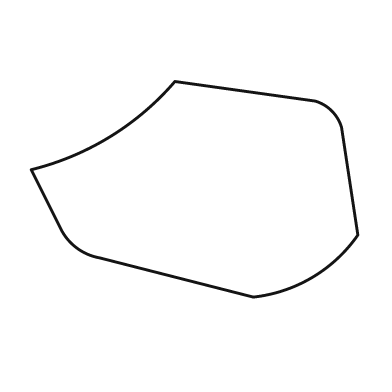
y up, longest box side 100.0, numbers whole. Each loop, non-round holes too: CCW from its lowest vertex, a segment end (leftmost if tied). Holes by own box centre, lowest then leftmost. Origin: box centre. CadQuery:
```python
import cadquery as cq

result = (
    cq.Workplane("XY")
    .moveTo(18.0, -33.0)
    .threePointArc((36.0, -27.0), (50.0, -14.0))
    .lineTo(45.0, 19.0)
    .threePointArc((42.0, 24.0), (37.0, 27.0))
    .lineTo(-6.0, 33.0)
    .threePointArc((-26.0, 16.0), (-50.0, 6.0))
    .lineTo(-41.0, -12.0)
    .threePointArc((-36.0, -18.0), (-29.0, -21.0))
    .close()
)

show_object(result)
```